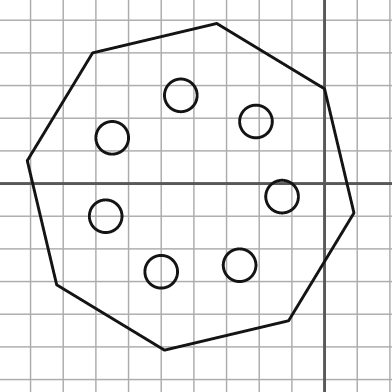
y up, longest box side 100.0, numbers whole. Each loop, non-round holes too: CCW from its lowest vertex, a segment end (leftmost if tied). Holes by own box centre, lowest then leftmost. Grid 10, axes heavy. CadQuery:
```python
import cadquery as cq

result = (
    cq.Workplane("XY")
    .moveTo(-49.0, -51.0)
    .lineTo(-11.0, -42.0)
    .lineTo(9.0, -9.0)
    .lineTo(0.0, 29.0)
    .lineTo(-33.0, 49.0)
    .lineTo(-71.0, 40.0)
    .lineTo(-91.0, 7.0)
    .lineTo(-82.0, -31.0)
    .close()
    .moveTo(-50.0, -27.0)
    .circle(5.0)
    .moveTo(-26.0, -25.0)
    .circle(5.0)
    .moveTo(-67.0, -10.0)
    .circle(5.0)
    .moveTo(-13.0, -4.0)
    .circle(5.0)
    .moveTo(-65.0, 14.0)
    .circle(5.0)
    .moveTo(-21.0, 19.0)
    .circle(5.0)
    .moveTo(-44.0, 27.0)
    .circle(5.0)
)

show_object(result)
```